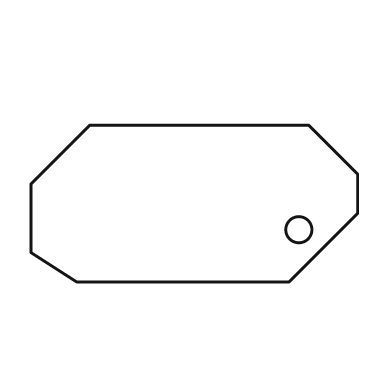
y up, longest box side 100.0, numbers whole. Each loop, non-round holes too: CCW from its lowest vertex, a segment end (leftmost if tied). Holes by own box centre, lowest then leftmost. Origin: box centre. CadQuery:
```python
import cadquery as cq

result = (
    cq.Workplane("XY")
    .moveTo(-36.0, -24.0)
    .lineTo(29.0, -24.0)
    .lineTo(50.0, -3.0)
    .lineTo(50.0, 9.0)
    .lineTo(35.0, 24.0)
    .lineTo(-32.0, 24.0)
    .lineTo(-50.0, 6.0)
    .lineTo(-50.0, -15.0)
    .close()
    .moveTo(32.0, -8.0)
    .circle(4.0)
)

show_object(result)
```